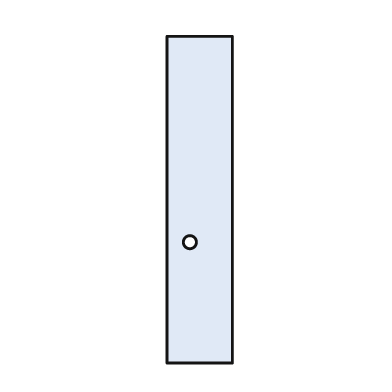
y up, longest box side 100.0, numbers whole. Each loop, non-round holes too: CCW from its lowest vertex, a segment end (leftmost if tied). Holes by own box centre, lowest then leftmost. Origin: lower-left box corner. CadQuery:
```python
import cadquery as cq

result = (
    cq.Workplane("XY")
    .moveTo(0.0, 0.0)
    .lineTo(20.0, 0.0)
    .lineTo(20.0, 100.0)
    .lineTo(0.0, 100.0)
    .close()
    .moveTo(7.0, 37.0)
    .circle(2.0)
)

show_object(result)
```